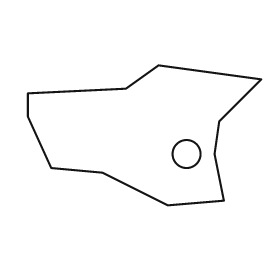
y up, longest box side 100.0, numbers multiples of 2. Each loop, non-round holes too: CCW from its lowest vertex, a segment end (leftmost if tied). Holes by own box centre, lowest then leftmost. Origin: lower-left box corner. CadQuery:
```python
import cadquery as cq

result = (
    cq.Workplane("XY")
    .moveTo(60.0, 0.0)
    .lineTo(84.0, 2.0)
    .lineTo(80.0, 22.0)
    .lineTo(82.0, 36.0)
    .lineTo(100.0, 54.0)
    .lineTo(56.0, 60.0)
    .lineTo(42.0, 50.0)
    .lineTo(0.0, 48.0)
    .lineTo(0.0, 38.0)
    .lineTo(10.0, 16.0)
    .lineTo(32.0, 14.0)
    .close()
    .moveTo(68.0, 22.0)
    .circle(6.0)
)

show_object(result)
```